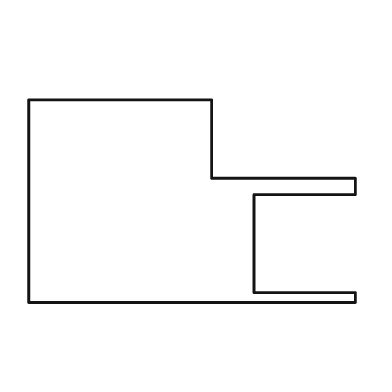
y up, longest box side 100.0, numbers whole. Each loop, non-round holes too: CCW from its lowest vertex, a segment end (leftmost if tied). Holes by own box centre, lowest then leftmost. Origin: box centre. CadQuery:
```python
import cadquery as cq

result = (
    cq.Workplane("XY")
    .moveTo(-50.0, -31.0)
    .lineTo(50.0, -31.0)
    .lineTo(50.0, -28.0)
    .lineTo(19.0, -28.0)
    .lineTo(19.0, 2.0)
    .lineTo(50.0, 2.0)
    .lineTo(50.0, 7.0)
    .lineTo(6.0, 7.0)
    .lineTo(6.0, 31.0)
    .lineTo(-50.0, 31.0)
    .close()
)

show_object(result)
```